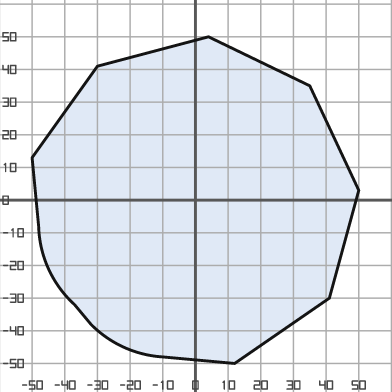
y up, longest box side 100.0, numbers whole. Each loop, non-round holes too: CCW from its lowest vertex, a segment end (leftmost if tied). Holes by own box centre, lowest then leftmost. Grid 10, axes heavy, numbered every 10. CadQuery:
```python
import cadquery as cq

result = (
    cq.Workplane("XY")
    .moveTo(12.0, -50.0)
    .lineTo(41.0, -30.0)
    .lineTo(50.0, 3.0)
    .lineTo(35.0, 35.0)
    .lineTo(4.0, 50.0)
    .lineTo(-30.0, 41.0)
    .lineTo(-50.0, 13.0)
    .lineTo(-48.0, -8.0)
    .threePointArc((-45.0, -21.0), (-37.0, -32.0))
    .lineTo(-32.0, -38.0)
    .threePointArc((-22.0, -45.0), (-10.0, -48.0))
    .close()
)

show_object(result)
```